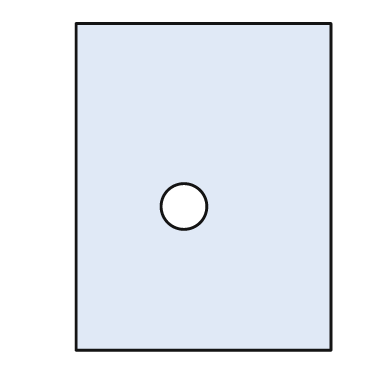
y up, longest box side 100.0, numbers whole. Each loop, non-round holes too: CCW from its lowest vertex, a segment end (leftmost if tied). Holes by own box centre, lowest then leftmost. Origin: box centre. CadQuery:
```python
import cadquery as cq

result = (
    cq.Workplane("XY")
    .moveTo(-39.0, -50.0)
    .lineTo(39.0, -50.0)
    .lineTo(39.0, 50.0)
    .lineTo(-39.0, 50.0)
    .close()
    .moveTo(-6.0, -6.0)
    .circle(7.0)
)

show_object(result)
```